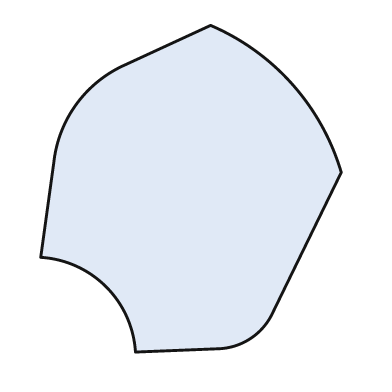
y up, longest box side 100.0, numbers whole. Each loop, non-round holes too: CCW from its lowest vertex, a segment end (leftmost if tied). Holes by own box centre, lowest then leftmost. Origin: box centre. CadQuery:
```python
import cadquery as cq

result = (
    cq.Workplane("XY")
    .moveTo(-17.0, -50.0)
    .lineTo(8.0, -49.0)
    .threePointArc((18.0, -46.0), (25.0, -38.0))
    .lineTo(46.0, 5.0)
    .threePointArc((31.0, 32.0), (6.0, 50.0))
    .lineTo(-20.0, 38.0)
    .threePointArc((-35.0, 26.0), (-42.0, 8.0))
    .lineTo(-46.0, -21.0)
    .threePointArc((-26.0, -30.0), (-17.0, -50.0))
    .close()
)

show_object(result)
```